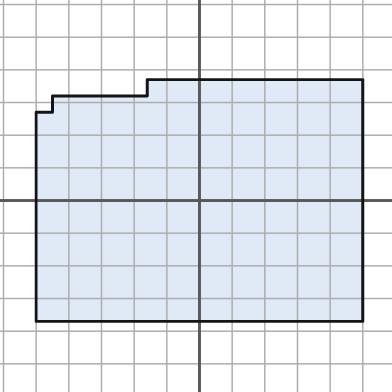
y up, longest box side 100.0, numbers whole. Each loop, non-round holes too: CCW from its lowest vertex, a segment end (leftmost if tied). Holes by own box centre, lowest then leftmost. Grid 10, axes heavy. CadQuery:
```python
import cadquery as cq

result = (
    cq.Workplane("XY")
    .moveTo(-50.0, -37.0)
    .lineTo(50.0, -37.0)
    .lineTo(50.0, 37.0)
    .lineTo(-16.0, 37.0)
    .lineTo(-16.0, 32.0)
    .lineTo(-45.0, 32.0)
    .lineTo(-45.0, 27.0)
    .lineTo(-50.0, 27.0)
    .close()
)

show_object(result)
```